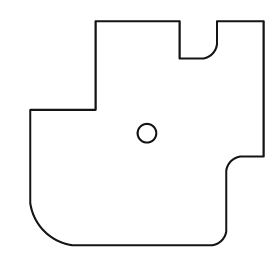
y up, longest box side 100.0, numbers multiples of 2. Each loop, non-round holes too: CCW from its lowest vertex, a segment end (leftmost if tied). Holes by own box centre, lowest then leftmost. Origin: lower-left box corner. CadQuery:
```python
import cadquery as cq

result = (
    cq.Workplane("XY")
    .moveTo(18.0, 0.0)
    .lineTo(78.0, 0.0)
    .threePointArc((82.0, 2.0), (84.0, 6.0))
    .lineTo(84.0, 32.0)
    .threePointArc((86.0, 36.0), (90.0, 38.0))
    .lineTo(100.0, 38.0)
    .lineTo(100.0, 96.0)
    .lineTo(80.0, 96.0)
    .lineTo(80.0, 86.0)
    .threePointArc((78.0, 82.0), (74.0, 80.0))
    .lineTo(64.0, 80.0)
    .lineTo(64.0, 96.0)
    .lineTo(28.0, 96.0)
    .lineTo(28.0, 58.0)
    .lineTo(0.0, 58.0)
    .lineTo(0.0, 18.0)
    .threePointArc((6.0, 6.0), (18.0, 0.0))
    .close()
    .moveTo(50.0, 48.0)
    .circle(4.0)
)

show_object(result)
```